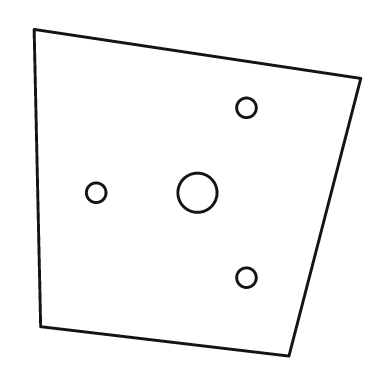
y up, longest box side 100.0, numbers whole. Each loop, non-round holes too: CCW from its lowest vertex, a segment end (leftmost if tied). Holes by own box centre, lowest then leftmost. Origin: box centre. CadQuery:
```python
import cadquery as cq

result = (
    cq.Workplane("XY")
    .moveTo(28.0, -50.0)
    .lineTo(50.0, 35.0)
    .lineTo(-50.0, 50.0)
    .lineTo(-48.0, -41.0)
    .close()
    .moveTo(15.0, -26.0)
    .circle(3.0)
    .moveTo(-31.0, 0.0)
    .circle(3.0)
    .moveTo(0.0, 0.0)
    .circle(6.0)
    .moveTo(15.0, 26.0)
    .circle(3.0)
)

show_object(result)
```